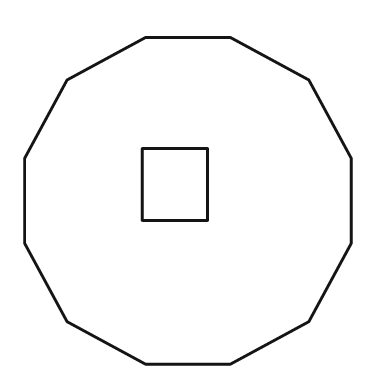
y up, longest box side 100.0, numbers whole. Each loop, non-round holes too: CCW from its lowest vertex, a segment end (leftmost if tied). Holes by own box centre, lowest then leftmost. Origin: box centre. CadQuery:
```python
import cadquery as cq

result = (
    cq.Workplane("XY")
    .moveTo(-13.0, -50.0)
    .lineTo(13.0, -50.0)
    .lineTo(37.0, -37.0)
    .lineTo(50.0, -13.0)
    .lineTo(50.0, 13.0)
    .lineTo(37.0, 37.0)
    .lineTo(13.0, 50.0)
    .lineTo(-13.0, 50.0)
    .lineTo(-37.0, 37.0)
    .lineTo(-50.0, 13.0)
    .lineTo(-50.0, -13.0)
    .lineTo(-37.0, -37.0)
    .close()
    .moveTo(-14.0, -6.0)
    .lineTo(6.0, -6.0)
    .lineTo(6.0, 16.0)
    .lineTo(-14.0, 16.0)
    .close()
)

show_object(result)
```